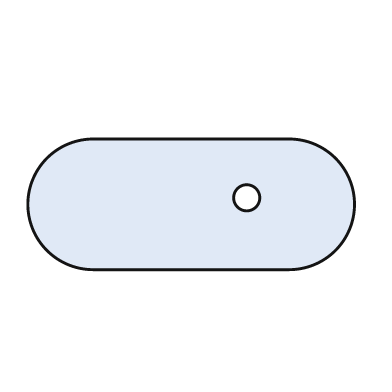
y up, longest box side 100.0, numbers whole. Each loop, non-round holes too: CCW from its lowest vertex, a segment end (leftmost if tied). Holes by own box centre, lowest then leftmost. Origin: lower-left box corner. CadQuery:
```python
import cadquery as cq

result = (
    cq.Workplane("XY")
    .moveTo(20.0, 0.0)
    .lineTo(80.0, 0.0)
    .threePointArc((100.0, 20.0), (80.0, 40.0))
    .lineTo(20.0, 40.0)
    .threePointArc((0.0, 20.0), (20.0, 0.0))
    .close()
    .moveTo(67.0, 22.0)
    .circle(4.0)
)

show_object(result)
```